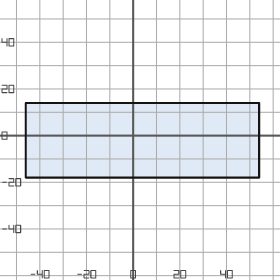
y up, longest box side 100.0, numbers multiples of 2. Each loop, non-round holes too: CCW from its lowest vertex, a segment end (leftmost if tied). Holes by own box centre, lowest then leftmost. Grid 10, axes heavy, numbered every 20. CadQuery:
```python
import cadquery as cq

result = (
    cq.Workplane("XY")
    .moveTo(-46.0, -18.0)
    .lineTo(54.0, -18.0)
    .lineTo(54.0, 14.0)
    .lineTo(-46.0, 14.0)
    .close()
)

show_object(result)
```